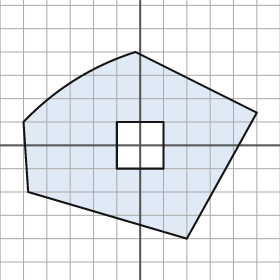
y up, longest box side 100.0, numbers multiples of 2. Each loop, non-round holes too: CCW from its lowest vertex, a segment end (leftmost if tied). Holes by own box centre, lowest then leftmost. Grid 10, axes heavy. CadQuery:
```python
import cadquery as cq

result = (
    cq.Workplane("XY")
    .moveTo(20.0, -40.0)
    .lineTo(50.0, 14.0)
    .lineTo(-2.0, 40.0)
    .threePointArc((-28.0, 28.0), (-50.0, 10.0))
    .lineTo(-48.0, -20.0)
    .close()
    .moveTo(-10.0, -10.0)
    .lineTo(10.0, -10.0)
    .lineTo(10.0, 10.0)
    .lineTo(-10.0, 10.0)
    .close()
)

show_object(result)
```